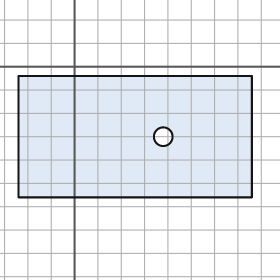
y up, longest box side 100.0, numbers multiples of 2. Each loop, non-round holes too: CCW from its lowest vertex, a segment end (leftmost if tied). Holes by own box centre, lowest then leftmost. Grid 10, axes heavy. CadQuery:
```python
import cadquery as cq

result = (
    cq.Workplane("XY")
    .moveTo(-24.0, -56.0)
    .lineTo(76.0, -56.0)
    .lineTo(76.0, -4.0)
    .lineTo(-24.0, -4.0)
    .close()
    .moveTo(38.0, -30.0)
    .circle(4.0)
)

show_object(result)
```